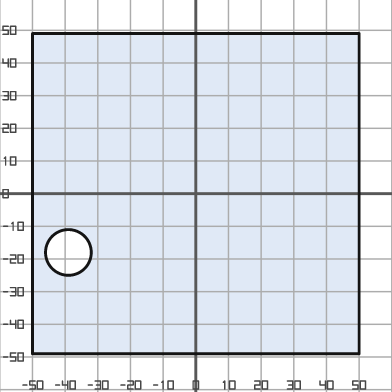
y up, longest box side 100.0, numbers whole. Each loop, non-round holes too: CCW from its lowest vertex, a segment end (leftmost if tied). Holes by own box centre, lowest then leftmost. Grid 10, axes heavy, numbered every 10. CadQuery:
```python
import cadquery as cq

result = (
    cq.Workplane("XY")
    .moveTo(-50.0, -49.0)
    .lineTo(50.0, -49.0)
    .lineTo(50.0, 49.0)
    .lineTo(-50.0, 49.0)
    .close()
    .moveTo(-39.0, -18.0)
    .circle(7.0)
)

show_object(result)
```